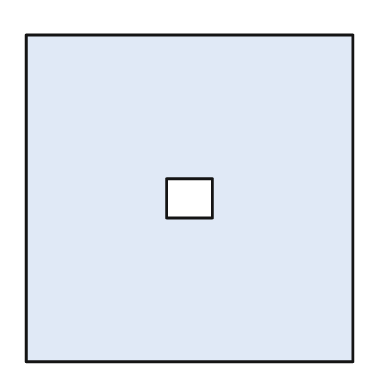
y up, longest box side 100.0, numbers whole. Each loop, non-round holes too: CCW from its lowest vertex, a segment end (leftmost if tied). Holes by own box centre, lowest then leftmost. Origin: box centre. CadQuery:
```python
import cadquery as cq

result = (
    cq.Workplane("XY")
    .moveTo(-50.0, -50.0)
    .lineTo(50.0, -50.0)
    .lineTo(50.0, 50.0)
    .lineTo(-50.0, 50.0)
    .close()
    .moveTo(-7.0, -6.0)
    .lineTo(7.0, -6.0)
    .lineTo(7.0, 6.0)
    .lineTo(-7.0, 6.0)
    .close()
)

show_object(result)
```